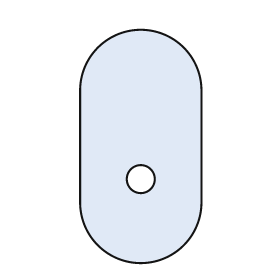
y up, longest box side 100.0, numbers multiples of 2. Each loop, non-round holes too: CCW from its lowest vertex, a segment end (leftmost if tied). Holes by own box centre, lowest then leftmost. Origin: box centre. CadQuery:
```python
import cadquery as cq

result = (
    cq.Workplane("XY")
    .moveTo(-26.0, -24.0)
    .threePointArc((0.0, -50.0), (26.0, -24.0))
    .lineTo(26.0, 24.0)
    .threePointArc((0.0, 50.0), (-26.0, 24.0))
    .close()
    .moveTo(0.0, -14.0)
    .circle(6.0)
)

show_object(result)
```